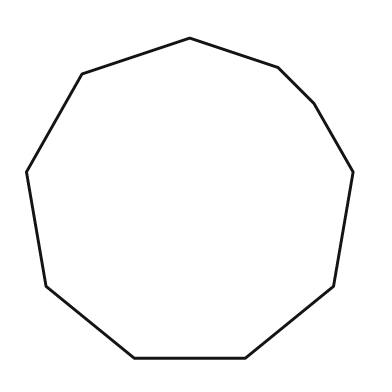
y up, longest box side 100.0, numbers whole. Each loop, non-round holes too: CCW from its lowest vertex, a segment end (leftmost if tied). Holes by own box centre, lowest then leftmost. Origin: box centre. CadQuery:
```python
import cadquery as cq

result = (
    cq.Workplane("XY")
    .moveTo(-17.0, -49.0)
    .lineTo(17.0, -49.0)
    .lineTo(44.0, -27.0)
    .lineTo(50.0, 8.0)
    .lineTo(38.0, 29.0)
    .lineTo(27.0, 40.0)
    .lineTo(0.0, 49.0)
    .lineTo(-33.0, 38.0)
    .lineTo(-50.0, 8.0)
    .lineTo(-44.0, -27.0)
    .close()
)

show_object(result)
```